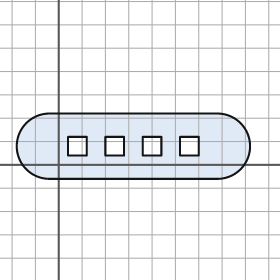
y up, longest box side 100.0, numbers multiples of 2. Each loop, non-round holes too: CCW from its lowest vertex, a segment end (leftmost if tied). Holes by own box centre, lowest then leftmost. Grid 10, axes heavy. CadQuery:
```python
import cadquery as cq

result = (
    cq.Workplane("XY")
    .moveTo(-4.0, -6.0)
    .lineTo(68.0, -6.0)
    .threePointArc((82.0, 8.0), (68.0, 22.0))
    .lineTo(-4.0, 22.0)
    .threePointArc((-18.0, 8.0), (-4.0, -6.0))
    .close()
    .moveTo(4.0, 4.0)
    .lineTo(12.0, 4.0)
    .lineTo(12.0, 12.0)
    .lineTo(4.0, 12.0)
    .close()
    .moveTo(20.0, 4.0)
    .lineTo(28.0, 4.0)
    .lineTo(28.0, 12.0)
    .lineTo(20.0, 12.0)
    .close()
    .moveTo(36.0, 4.0)
    .lineTo(44.0, 4.0)
    .lineTo(44.0, 12.0)
    .lineTo(36.0, 12.0)
    .close()
    .moveTo(52.0, 4.0)
    .lineTo(60.0, 4.0)
    .lineTo(60.0, 12.0)
    .lineTo(52.0, 12.0)
    .close()
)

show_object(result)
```